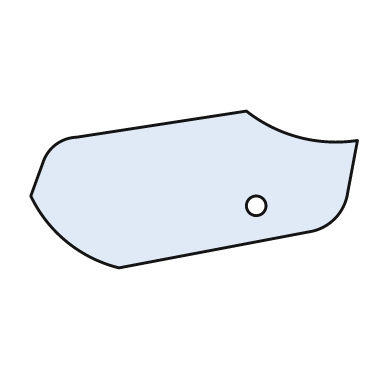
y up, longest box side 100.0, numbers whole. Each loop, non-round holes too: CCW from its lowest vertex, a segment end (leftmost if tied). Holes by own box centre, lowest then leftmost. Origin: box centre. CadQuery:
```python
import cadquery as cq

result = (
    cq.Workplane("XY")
    .moveTo(-23.0, -24.0)
    .lineTo(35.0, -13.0)
    .threePointArc((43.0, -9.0), (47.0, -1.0))
    .lineTo(50.0, 15.0)
    .threePointArc((32.0, 16.0), (16.0, 24.0))
    .lineTo(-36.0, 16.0)
    .threePointArc((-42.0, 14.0), (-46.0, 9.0))
    .lineTo(-50.0, -2.0)
    .threePointArc((-39.0, -16.0), (-23.0, -24.0))
    .close()
    .moveTo(19.0, -5.0)
    .circle(3.0)
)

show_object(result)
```